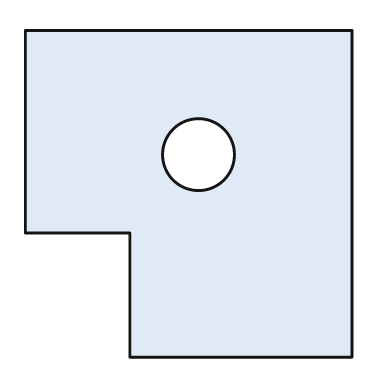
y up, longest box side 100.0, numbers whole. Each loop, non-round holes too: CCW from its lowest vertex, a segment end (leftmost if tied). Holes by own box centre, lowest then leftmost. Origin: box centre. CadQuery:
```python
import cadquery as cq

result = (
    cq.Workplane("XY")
    .moveTo(-18.0, -50.0)
    .lineTo(50.0, -50.0)
    .lineTo(50.0, 50.0)
    .lineTo(-50.0, 50.0)
    .lineTo(-50.0, -12.0)
    .lineTo(-18.0, -12.0)
    .close()
    .moveTo(3.0, 12.0)
    .circle(11.0)
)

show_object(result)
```